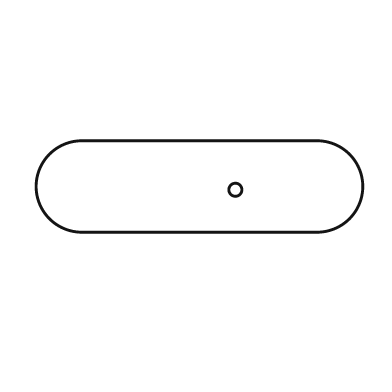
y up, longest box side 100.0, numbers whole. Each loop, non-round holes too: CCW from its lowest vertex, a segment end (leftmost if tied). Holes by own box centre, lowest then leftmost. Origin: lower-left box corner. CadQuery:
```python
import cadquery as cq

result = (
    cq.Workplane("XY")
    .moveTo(14.0, 0.0)
    .lineTo(86.0, 0.0)
    .threePointArc((100.0, 14.0), (86.0, 28.0))
    .lineTo(14.0, 28.0)
    .threePointArc((0.0, 14.0), (14.0, 0.0))
    .close()
    .moveTo(61.0, 13.0)
    .circle(2.0)
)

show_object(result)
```